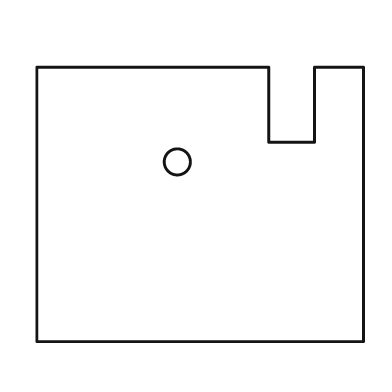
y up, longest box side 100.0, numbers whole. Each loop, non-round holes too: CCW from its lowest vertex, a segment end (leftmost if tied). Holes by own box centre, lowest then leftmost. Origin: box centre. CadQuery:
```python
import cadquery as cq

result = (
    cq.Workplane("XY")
    .moveTo(-50.0, -42.0)
    .lineTo(50.0, -42.0)
    .lineTo(50.0, 42.0)
    .lineTo(35.0, 42.0)
    .lineTo(35.0, 19.0)
    .lineTo(21.0, 19.0)
    .lineTo(21.0, 42.0)
    .lineTo(-50.0, 42.0)
    .close()
    .moveTo(-7.0, 13.0)
    .circle(4.0)
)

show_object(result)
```